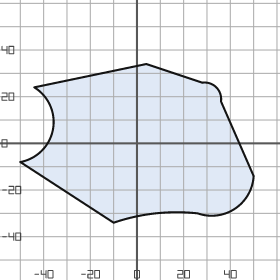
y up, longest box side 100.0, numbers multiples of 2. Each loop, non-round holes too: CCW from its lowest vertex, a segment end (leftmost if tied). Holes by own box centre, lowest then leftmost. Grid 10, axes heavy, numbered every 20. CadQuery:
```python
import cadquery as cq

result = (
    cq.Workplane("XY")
    .moveTo(-10.0, -34.0)
    .threePointArc((8.0, -30.0), (26.0, -30.0))
    .threePointArc((42.0, -28.0), (50.0, -14.0))
    .lineTo(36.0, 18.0)
    .threePointArc((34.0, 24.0), (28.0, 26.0))
    .lineTo(4.0, 34.0)
    .lineTo(-44.0, 24.0)
    .threePointArc((-36.0, 6.0), (-50.0, -8.0))
    .close()
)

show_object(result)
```